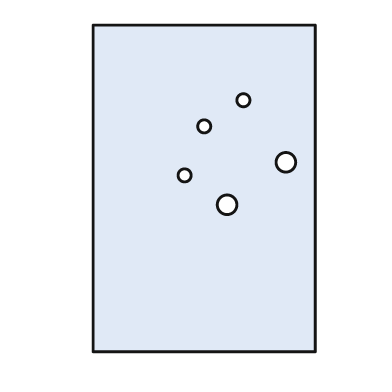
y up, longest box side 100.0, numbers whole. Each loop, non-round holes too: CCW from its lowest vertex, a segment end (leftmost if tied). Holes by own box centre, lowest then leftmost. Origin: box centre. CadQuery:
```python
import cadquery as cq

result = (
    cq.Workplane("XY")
    .moveTo(-34.0, -50.0)
    .lineTo(34.0, -50.0)
    .lineTo(34.0, 50.0)
    .lineTo(-34.0, 50.0)
    .close()
    .moveTo(7.0, -5.0)
    .circle(3.0)
    .moveTo(-6.0, 4.0)
    .circle(2.0)
    .moveTo(25.0, 8.0)
    .circle(3.0)
    .moveTo(0.0, 19.0)
    .circle(2.0)
    .moveTo(12.0, 27.0)
    .circle(2.0)
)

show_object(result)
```